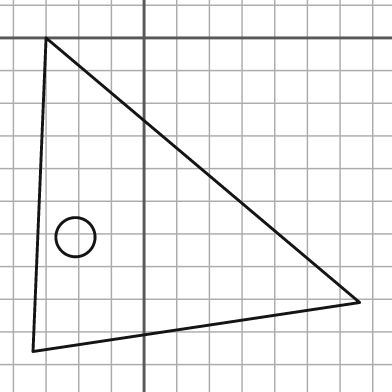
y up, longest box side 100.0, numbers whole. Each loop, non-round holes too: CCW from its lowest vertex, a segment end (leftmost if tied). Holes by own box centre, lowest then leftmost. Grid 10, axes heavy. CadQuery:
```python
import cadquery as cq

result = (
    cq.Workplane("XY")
    .moveTo(-34.0, -96.0)
    .lineTo(66.0, -81.0)
    .lineTo(-30.0, 0.0)
    .close()
    .moveTo(-21.0, -61.0)
    .circle(6.0)
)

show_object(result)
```